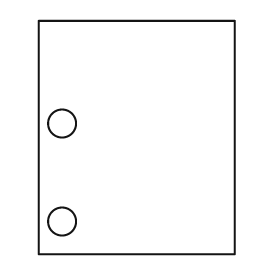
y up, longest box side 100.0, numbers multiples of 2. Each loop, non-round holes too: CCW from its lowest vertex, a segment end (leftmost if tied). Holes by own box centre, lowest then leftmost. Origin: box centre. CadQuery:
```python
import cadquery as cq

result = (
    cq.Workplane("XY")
    .moveTo(-42.0, -50.0)
    .lineTo(42.0, -50.0)
    .lineTo(42.0, 50.0)
    .lineTo(-42.0, 50.0)
    .close()
    .moveTo(-32.0, -36.0)
    .circle(6.0)
    .moveTo(-32.0, 6.0)
    .circle(6.0)
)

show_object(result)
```